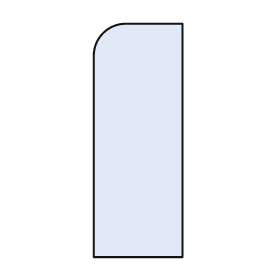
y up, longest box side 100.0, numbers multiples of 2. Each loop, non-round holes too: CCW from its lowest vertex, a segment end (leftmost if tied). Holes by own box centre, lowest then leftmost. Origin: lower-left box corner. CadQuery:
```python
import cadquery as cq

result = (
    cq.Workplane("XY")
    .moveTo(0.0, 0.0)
    .lineTo(38.0, 0.0)
    .lineTo(38.0, 100.0)
    .lineTo(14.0, 100.0)
    .threePointArc((4.0, 96.0), (0.0, 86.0))
    .close()
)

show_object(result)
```